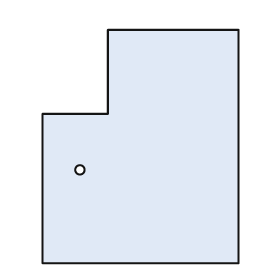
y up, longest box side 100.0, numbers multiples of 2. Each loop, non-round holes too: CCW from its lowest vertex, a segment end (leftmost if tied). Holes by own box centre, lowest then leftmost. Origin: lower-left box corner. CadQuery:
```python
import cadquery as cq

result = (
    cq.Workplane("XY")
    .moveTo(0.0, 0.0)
    .lineTo(84.0, 0.0)
    .lineTo(84.0, 100.0)
    .lineTo(28.0, 100.0)
    .lineTo(28.0, 64.0)
    .lineTo(0.0, 64.0)
    .close()
    .moveTo(16.0, 40.0)
    .circle(2.0)
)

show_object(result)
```